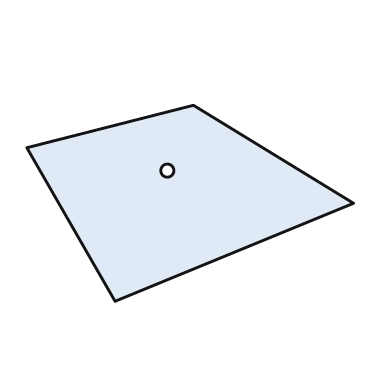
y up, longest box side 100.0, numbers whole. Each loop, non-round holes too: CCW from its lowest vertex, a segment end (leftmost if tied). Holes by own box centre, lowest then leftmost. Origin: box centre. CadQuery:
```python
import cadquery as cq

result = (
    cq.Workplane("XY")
    .moveTo(-23.0, -30.0)
    .lineTo(50.0, 0.0)
    .lineTo(1.0, 30.0)
    .lineTo(-50.0, 17.0)
    .close()
    .moveTo(-7.0, 10.0)
    .circle(2.0)
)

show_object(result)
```